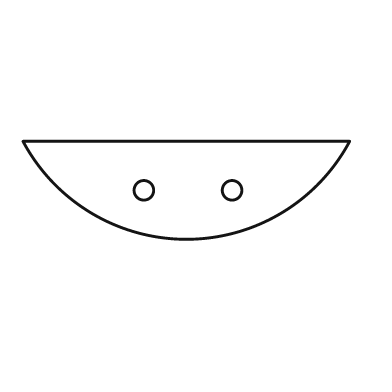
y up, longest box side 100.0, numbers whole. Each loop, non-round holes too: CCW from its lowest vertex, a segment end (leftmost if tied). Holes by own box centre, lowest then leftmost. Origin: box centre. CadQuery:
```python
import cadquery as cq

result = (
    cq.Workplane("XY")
    .moveTo(-50.0, 15.0)
    .threePointArc((0.0, -15.0), (50.0, 15.0))
    .close()
    .moveTo(-13.0, 0.0)
    .circle(3.0)
    .moveTo(14.0, 0.0)
    .circle(3.0)
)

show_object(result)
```